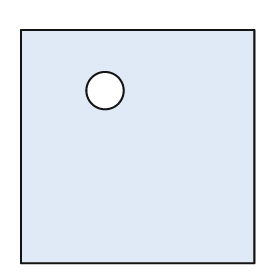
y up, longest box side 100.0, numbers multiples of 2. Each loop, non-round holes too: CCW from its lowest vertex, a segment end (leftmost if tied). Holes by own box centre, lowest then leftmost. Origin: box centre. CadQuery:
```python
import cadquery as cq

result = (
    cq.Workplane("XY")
    .moveTo(-50.0, -50.0)
    .lineTo(50.0, -50.0)
    .lineTo(50.0, 50.0)
    .lineTo(-50.0, 50.0)
    .close()
    .moveTo(-14.0, 24.0)
    .circle(8.0)
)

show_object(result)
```